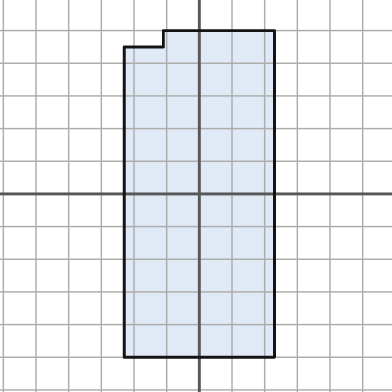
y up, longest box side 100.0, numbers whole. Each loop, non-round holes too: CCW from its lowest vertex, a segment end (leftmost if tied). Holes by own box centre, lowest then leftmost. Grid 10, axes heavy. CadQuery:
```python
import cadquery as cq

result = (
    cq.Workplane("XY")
    .moveTo(-23.0, -50.0)
    .lineTo(23.0, -50.0)
    .lineTo(23.0, 50.0)
    .lineTo(-11.0, 50.0)
    .lineTo(-11.0, 45.0)
    .lineTo(-23.0, 45.0)
    .close()
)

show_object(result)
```